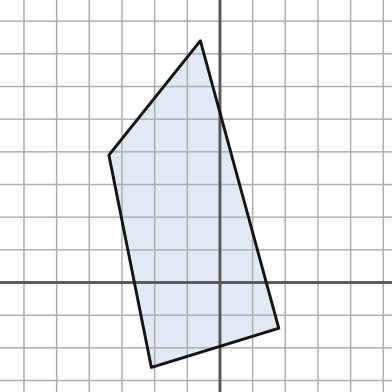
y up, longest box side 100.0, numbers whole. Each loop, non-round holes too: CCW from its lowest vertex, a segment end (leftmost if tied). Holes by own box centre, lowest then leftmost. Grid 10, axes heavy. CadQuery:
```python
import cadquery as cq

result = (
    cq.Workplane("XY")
    .moveTo(-21.0, -26.0)
    .lineTo(18.0, -14.0)
    .lineTo(-6.0, 74.0)
    .lineTo(-34.0, 39.0)
    .close()
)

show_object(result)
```